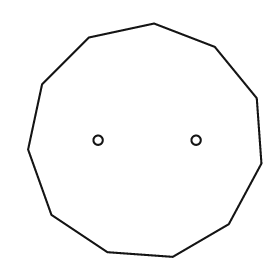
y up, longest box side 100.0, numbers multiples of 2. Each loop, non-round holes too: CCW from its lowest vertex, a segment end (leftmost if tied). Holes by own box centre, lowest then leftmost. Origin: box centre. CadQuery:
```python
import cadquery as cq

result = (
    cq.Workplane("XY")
    .moveTo(12.0, -50.0)
    .lineTo(36.0, -36.0)
    .lineTo(50.0, -10.0)
    .lineTo(48.0, 18.0)
    .lineTo(30.0, 40.0)
    .lineTo(4.0, 50.0)
    .lineTo(-24.0, 44.0)
    .lineTo(-44.0, 24.0)
    .lineTo(-50.0, -4.0)
    .lineTo(-40.0, -32.0)
    .lineTo(-16.0, -48.0)
    .close()
    .moveTo(-20.0, 0.0)
    .circle(2.0)
    .moveTo(22.0, 0.0)
    .circle(2.0)
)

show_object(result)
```